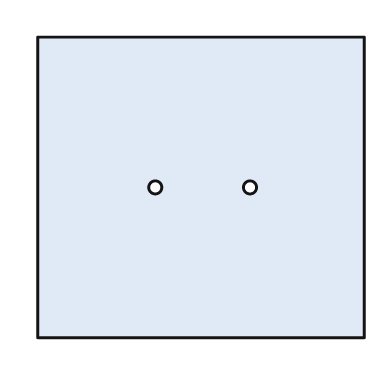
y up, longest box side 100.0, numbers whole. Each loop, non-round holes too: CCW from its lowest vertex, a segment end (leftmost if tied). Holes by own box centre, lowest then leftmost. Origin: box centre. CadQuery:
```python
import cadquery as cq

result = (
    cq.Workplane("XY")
    .moveTo(-50.0, -46.0)
    .lineTo(50.0, -46.0)
    .lineTo(50.0, 46.0)
    .lineTo(-50.0, 46.0)
    .close()
    .moveTo(-14.0, 0.0)
    .circle(2.0)
    .moveTo(15.0, 0.0)
    .circle(2.0)
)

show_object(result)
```